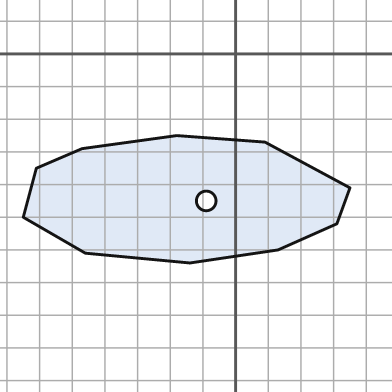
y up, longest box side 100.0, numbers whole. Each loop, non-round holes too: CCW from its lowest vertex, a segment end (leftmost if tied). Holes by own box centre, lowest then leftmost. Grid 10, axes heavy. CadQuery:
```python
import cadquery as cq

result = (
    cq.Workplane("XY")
    .moveTo(-14.0, -64.0)
    .lineTo(13.0, -60.0)
    .lineTo(31.0, -52.0)
    .lineTo(35.0, -41.0)
    .lineTo(9.0, -27.0)
    .lineTo(-18.0, -25.0)
    .lineTo(-47.0, -29.0)
    .lineTo(-61.0, -35.0)
    .lineTo(-65.0, -50.0)
    .lineTo(-46.0, -61.0)
    .close()
    .moveTo(-9.0, -45.0)
    .circle(3.0)
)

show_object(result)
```